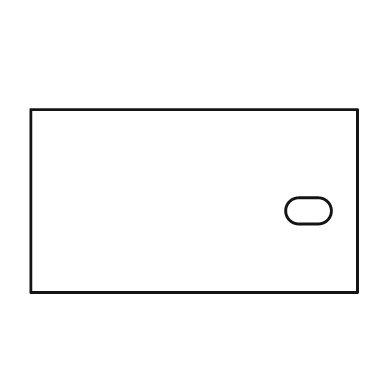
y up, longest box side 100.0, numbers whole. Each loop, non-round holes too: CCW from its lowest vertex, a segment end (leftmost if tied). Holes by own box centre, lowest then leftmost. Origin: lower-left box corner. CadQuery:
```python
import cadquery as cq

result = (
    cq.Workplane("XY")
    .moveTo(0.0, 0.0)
    .lineTo(100.0, 0.0)
    .lineTo(100.0, 56.0)
    .lineTo(0.0, 56.0)
    .close()
    .moveTo(82.0, 21.0)
    .lineTo(88.0, 21.0)
    .threePointArc((92.0, 25.0), (88.0, 29.0))
    .lineTo(82.0, 29.0)
    .threePointArc((78.0, 25.0), (82.0, 21.0))
    .close()
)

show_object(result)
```